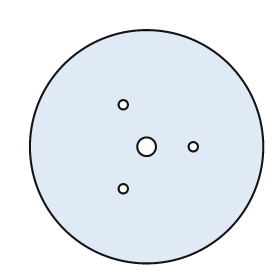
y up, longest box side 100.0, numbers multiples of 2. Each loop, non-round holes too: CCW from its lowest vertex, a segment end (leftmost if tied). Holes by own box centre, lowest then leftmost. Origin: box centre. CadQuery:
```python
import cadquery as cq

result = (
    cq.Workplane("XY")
    .moveTo(0.0, 0.0)
    .circle(50.0)
    .moveTo(-10.0, -18.0)
    .circle(2.0)
    .moveTo(0.0, 0.0)
    .circle(4.0)
    .moveTo(20.0, 0.0)
    .circle(2.0)
    .moveTo(-10.0, 18.0)
    .circle(2.0)
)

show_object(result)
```